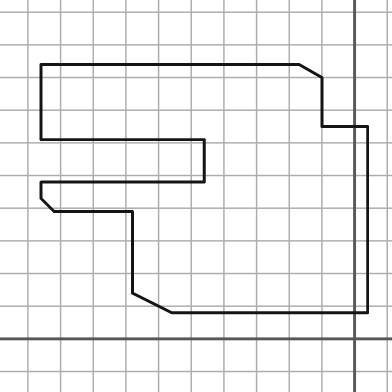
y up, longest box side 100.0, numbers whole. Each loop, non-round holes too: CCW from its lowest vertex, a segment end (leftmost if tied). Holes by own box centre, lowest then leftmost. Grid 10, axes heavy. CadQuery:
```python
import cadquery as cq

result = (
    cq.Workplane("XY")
    .moveTo(-56.0, 8.0)
    .lineTo(4.0, 8.0)
    .lineTo(4.0, 65.0)
    .lineTo(-10.0, 65.0)
    .lineTo(-10.0, 80.0)
    .lineTo(-17.0, 84.0)
    .lineTo(-96.0, 84.0)
    .lineTo(-96.0, 61.0)
    .lineTo(-46.0, 61.0)
    .lineTo(-46.0, 48.0)
    .lineTo(-96.0, 48.0)
    .lineTo(-96.0, 43.0)
    .lineTo(-92.0, 39.0)
    .lineTo(-68.0, 39.0)
    .lineTo(-68.0, 14.0)
    .close()
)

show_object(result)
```